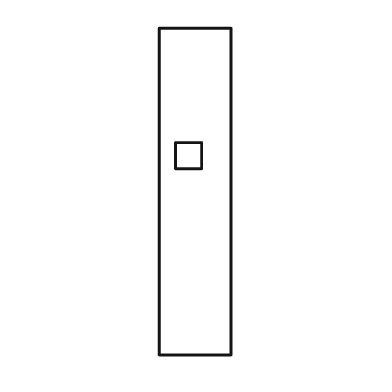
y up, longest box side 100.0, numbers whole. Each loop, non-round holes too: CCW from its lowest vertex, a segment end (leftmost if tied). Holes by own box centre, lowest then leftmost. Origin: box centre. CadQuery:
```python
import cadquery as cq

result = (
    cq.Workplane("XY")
    .moveTo(-11.0, -50.0)
    .lineTo(11.0, -50.0)
    .lineTo(11.0, 50.0)
    .lineTo(-11.0, 50.0)
    .close()
    .moveTo(-6.0, 7.0)
    .lineTo(2.0, 7.0)
    .lineTo(2.0, 15.0)
    .lineTo(-6.0, 15.0)
    .close()
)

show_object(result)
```